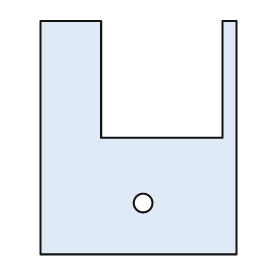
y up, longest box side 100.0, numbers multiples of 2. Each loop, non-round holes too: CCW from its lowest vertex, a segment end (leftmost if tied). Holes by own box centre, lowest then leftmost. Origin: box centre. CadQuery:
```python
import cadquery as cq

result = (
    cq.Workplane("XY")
    .moveTo(-42.0, -50.0)
    .lineTo(42.0, -50.0)
    .lineTo(42.0, 50.0)
    .lineTo(36.0, 50.0)
    .lineTo(36.0, 0.0)
    .lineTo(-16.0, 0.0)
    .lineTo(-16.0, 50.0)
    .lineTo(-42.0, 50.0)
    .close()
    .moveTo(2.0, -28.0)
    .circle(4.0)
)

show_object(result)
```